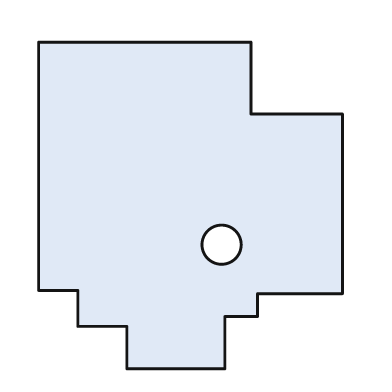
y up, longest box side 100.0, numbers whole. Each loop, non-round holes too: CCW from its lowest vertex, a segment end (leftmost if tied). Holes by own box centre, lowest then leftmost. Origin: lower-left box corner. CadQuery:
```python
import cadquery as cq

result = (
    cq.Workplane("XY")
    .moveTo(27.0, 0.0)
    .lineTo(57.0, 0.0)
    .lineTo(57.0, 16.0)
    .lineTo(67.0, 16.0)
    .lineTo(67.0, 23.0)
    .lineTo(93.0, 23.0)
    .lineTo(93.0, 78.0)
    .lineTo(65.0, 78.0)
    .lineTo(65.0, 100.0)
    .lineTo(0.0, 100.0)
    .lineTo(0.0, 24.0)
    .lineTo(12.0, 24.0)
    .lineTo(12.0, 13.0)
    .lineTo(27.0, 13.0)
    .close()
    .moveTo(56.0, 38.0)
    .circle(6.0)
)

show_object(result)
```